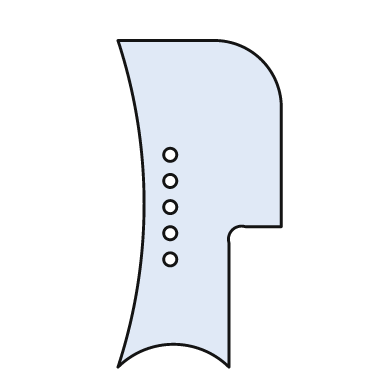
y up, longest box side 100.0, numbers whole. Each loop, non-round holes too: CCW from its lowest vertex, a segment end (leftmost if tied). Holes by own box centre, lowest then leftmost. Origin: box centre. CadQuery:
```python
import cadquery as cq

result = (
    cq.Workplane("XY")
    .moveTo(-25.0, -50.0)
    .threePointArc((-8.0, -43.0), (9.0, -50.0))
    .lineTo(9.0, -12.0)
    .threePointArc((10.0, -8.0), (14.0, -7.0))
    .lineTo(25.0, -7.0)
    .lineTo(25.0, 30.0)
    .threePointArc((19.0, 44.0), (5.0, 50.0))
    .lineTo(-25.0, 50.0)
    .threePointArc((-17.0, 0.0), (-25.0, -50.0))
    .close()
    .moveTo(-9.0, -17.0)
    .circle(2.0)
    .moveTo(-9.0, -9.0)
    .circle(2.0)
    .moveTo(-9.0, -1.0)
    .circle(2.0)
    .moveTo(-9.0, 7.0)
    .circle(2.0)
    .moveTo(-9.0, 15.0)
    .circle(2.0)
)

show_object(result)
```